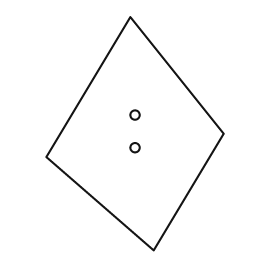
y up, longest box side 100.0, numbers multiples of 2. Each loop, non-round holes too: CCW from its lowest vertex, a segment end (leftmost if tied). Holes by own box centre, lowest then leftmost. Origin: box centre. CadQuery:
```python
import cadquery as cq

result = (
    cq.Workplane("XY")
    .moveTo(8.0, -50.0)
    .lineTo(38.0, 0.0)
    .lineTo(-2.0, 50.0)
    .lineTo(-38.0, -10.0)
    .close()
    .moveTo(0.0, -6.0)
    .circle(2.0)
    .moveTo(0.0, 8.0)
    .circle(2.0)
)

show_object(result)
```